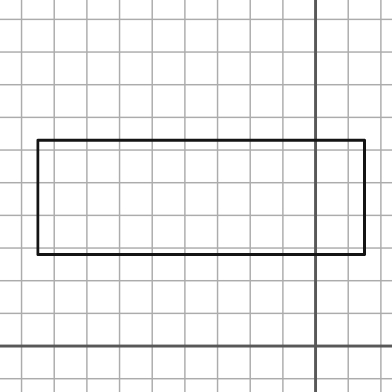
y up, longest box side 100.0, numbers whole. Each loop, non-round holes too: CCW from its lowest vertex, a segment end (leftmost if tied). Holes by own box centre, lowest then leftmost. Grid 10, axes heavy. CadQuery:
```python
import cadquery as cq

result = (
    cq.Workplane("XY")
    .moveTo(-85.0, 28.0)
    .lineTo(15.0, 28.0)
    .lineTo(15.0, 63.0)
    .lineTo(-85.0, 63.0)
    .close()
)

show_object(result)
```